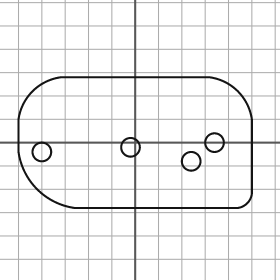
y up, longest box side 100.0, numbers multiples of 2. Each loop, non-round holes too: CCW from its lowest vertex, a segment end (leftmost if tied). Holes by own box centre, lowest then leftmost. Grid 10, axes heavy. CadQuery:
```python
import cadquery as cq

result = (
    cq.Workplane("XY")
    .moveTo(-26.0, -28.0)
    .lineTo(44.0, -28.0)
    .threePointArc((48.0, -26.0), (50.0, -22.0))
    .lineTo(50.0, 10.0)
    .threePointArc((44.0, 22.0), (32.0, 28.0))
    .lineTo(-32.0, 28.0)
    .threePointArc((-44.0, 22.0), (-50.0, 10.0))
    .lineTo(-50.0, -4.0)
    .threePointArc((-42.0, -20.0), (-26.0, -28.0))
    .close()
    .moveTo(24.0, -8.0)
    .circle(4.0)
    .moveTo(-40.0, -4.0)
    .circle(4.0)
    .moveTo(-2.0, -2.0)
    .circle(4.0)
    .moveTo(34.0, 0.0)
    .circle(4.0)
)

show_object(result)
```